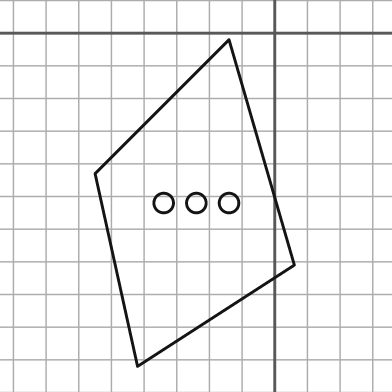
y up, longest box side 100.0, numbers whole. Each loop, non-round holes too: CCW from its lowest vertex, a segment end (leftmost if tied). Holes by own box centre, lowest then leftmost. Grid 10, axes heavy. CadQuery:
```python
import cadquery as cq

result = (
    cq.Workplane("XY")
    .moveTo(-42.0, -102.0)
    .lineTo(6.0, -71.0)
    .lineTo(-14.0, -2.0)
    .lineTo(-55.0, -43.0)
    .close()
    .moveTo(-34.0, -52.0)
    .circle(3.0)
    .moveTo(-24.0, -52.0)
    .circle(3.0)
    .moveTo(-14.0, -52.0)
    .circle(3.0)
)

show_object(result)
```